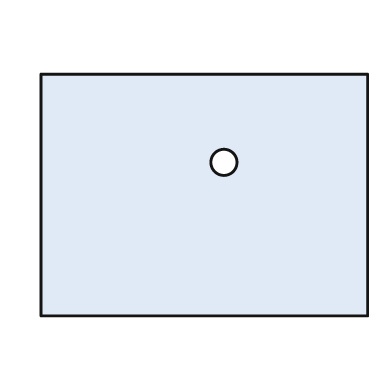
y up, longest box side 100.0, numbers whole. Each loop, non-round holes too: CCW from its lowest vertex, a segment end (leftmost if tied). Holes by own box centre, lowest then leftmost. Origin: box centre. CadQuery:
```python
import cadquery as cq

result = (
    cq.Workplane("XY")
    .moveTo(-50.0, -37.0)
    .lineTo(50.0, -37.0)
    .lineTo(50.0, 37.0)
    .lineTo(-50.0, 37.0)
    .close()
    .moveTo(6.0, 10.0)
    .circle(4.0)
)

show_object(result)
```